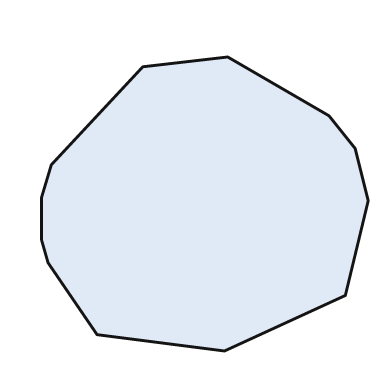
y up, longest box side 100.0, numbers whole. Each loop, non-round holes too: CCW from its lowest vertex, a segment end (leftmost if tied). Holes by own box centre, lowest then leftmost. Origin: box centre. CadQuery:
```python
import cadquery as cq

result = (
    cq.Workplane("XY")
    .moveTo(6.0, -45.0)
    .lineTo(43.0, -28.0)
    .lineTo(50.0, 1.0)
    .lineTo(46.0, 17.0)
    .lineTo(38.0, 27.0)
    .lineTo(7.0, 45.0)
    .lineTo(-19.0, 42.0)
    .lineTo(-47.0, 12.0)
    .lineTo(-50.0, 2.0)
    .lineTo(-50.0, -11.0)
    .lineTo(-48.0, -18.0)
    .lineTo(-33.0, -40.0)
    .close()
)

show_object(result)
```